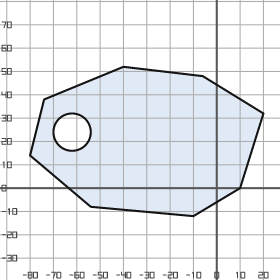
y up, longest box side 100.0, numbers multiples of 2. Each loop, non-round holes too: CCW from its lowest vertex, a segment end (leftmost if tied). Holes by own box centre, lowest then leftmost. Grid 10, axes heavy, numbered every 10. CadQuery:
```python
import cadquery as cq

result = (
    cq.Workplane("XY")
    .moveTo(-10.0, -12.0)
    .lineTo(10.0, 0.0)
    .lineTo(20.0, 32.0)
    .lineTo(-6.0, 48.0)
    .lineTo(-40.0, 52.0)
    .lineTo(-74.0, 38.0)
    .lineTo(-80.0, 14.0)
    .lineTo(-54.0, -8.0)
    .close()
    .moveTo(-62.0, 24.0)
    .circle(8.0)
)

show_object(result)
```